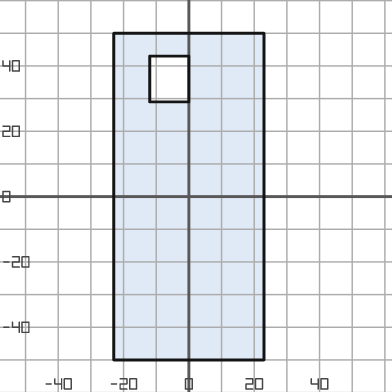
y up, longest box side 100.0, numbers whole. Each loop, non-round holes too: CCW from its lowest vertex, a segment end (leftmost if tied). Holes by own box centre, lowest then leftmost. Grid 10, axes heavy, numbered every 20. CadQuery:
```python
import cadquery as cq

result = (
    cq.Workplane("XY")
    .moveTo(-23.0, -50.0)
    .lineTo(23.0, -50.0)
    .lineTo(23.0, 50.0)
    .lineTo(-23.0, 50.0)
    .close()
    .moveTo(-12.0, 29.0)
    .lineTo(0.0, 29.0)
    .lineTo(0.0, 43.0)
    .lineTo(-12.0, 43.0)
    .close()
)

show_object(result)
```